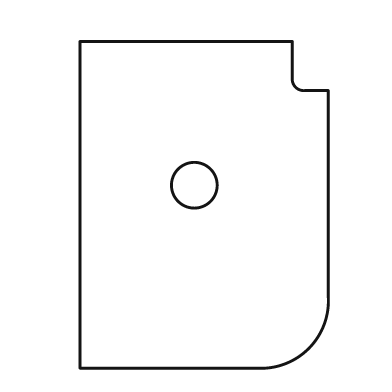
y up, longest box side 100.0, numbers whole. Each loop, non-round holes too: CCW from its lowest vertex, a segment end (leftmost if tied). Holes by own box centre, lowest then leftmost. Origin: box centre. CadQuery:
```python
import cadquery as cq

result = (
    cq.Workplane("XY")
    .moveTo(-38.0, -50.0)
    .lineTo(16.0, -50.0)
    .threePointArc((32.0, -44.0), (38.0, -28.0))
    .lineTo(38.0, 35.0)
    .lineTo(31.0, 35.0)
    .threePointArc((28.0, 36.0), (27.0, 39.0))
    .lineTo(27.0, 50.0)
    .lineTo(-38.0, 50.0)
    .close()
    .moveTo(-3.0, 6.0)
    .circle(7.0)
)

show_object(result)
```